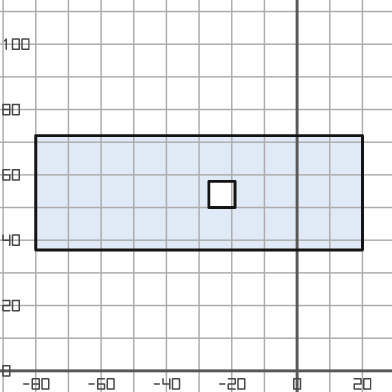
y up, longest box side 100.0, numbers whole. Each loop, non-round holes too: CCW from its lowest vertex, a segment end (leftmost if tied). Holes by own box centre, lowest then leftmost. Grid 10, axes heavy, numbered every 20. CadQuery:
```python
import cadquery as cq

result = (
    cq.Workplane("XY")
    .moveTo(-80.0, 37.0)
    .lineTo(20.0, 37.0)
    .lineTo(20.0, 72.0)
    .lineTo(-80.0, 72.0)
    .close()
    .moveTo(-27.0, 50.0)
    .lineTo(-19.0, 50.0)
    .lineTo(-19.0, 58.0)
    .lineTo(-27.0, 58.0)
    .close()
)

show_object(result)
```